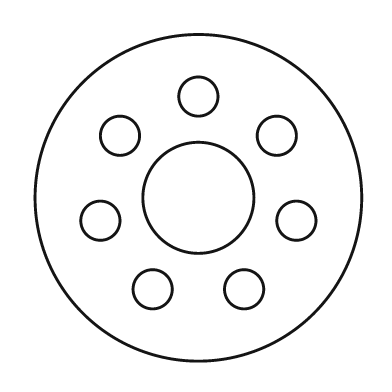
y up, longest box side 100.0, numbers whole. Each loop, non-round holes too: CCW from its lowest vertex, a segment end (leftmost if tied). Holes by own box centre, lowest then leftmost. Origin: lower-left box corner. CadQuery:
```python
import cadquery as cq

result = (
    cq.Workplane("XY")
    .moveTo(50.0, 50.0)
    .circle(50.0)
    .moveTo(36.0, 22.0)
    .circle(6.0)
    .moveTo(64.0, 22.0)
    .circle(6.0)
    .moveTo(20.0, 43.0)
    .circle(6.0)
    .moveTo(80.0, 43.0)
    .circle(6.0)
    .moveTo(50.0, 50.0)
    .circle(17.0)
    .moveTo(26.0, 69.0)
    .circle(6.0)
    .moveTo(74.0, 69.0)
    .circle(6.0)
    .moveTo(50.0, 81.0)
    .circle(6.0)
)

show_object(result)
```